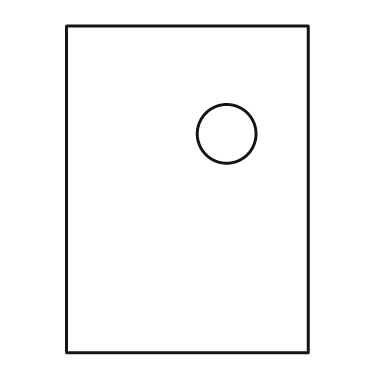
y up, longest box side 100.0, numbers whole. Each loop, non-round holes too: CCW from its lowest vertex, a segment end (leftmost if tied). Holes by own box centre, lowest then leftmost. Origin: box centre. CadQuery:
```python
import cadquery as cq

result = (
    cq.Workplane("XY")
    .moveTo(-37.0, -50.0)
    .lineTo(37.0, -50.0)
    .lineTo(37.0, 50.0)
    .lineTo(-37.0, 50.0)
    .close()
    .moveTo(12.0, 17.0)
    .circle(9.0)
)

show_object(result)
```